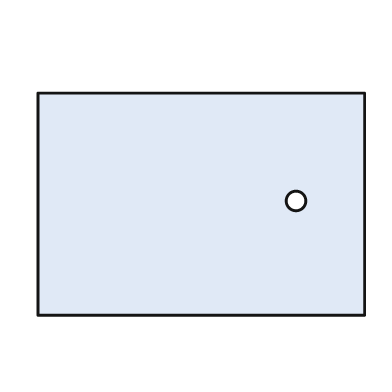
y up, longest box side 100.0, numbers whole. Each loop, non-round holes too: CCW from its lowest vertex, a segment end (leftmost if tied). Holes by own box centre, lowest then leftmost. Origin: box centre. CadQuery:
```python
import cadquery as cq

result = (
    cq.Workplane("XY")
    .moveTo(-50.0, -34.0)
    .lineTo(50.0, -34.0)
    .lineTo(50.0, 34.0)
    .lineTo(-50.0, 34.0)
    .close()
    .moveTo(29.0, 1.0)
    .circle(3.0)
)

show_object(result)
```